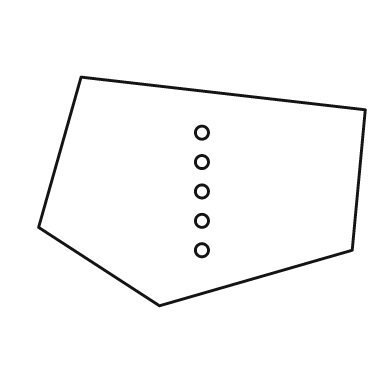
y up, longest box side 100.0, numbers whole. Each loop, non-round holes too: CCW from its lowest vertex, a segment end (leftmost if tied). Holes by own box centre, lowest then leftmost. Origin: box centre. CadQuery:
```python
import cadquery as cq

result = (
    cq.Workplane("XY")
    .moveTo(-13.0, -35.0)
    .lineTo(46.0, -18.0)
    .lineTo(50.0, 25.0)
    .lineTo(-37.0, 35.0)
    .lineTo(-50.0, -11.0)
    .close()
    .moveTo(0.0, -18.0)
    .circle(2.0)
    .moveTo(0.0, -9.0)
    .circle(2.0)
    .moveTo(0.0, 0.0)
    .circle(2.0)
    .moveTo(0.0, 9.0)
    .circle(2.0)
    .moveTo(0.0, 18.0)
    .circle(2.0)
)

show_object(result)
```